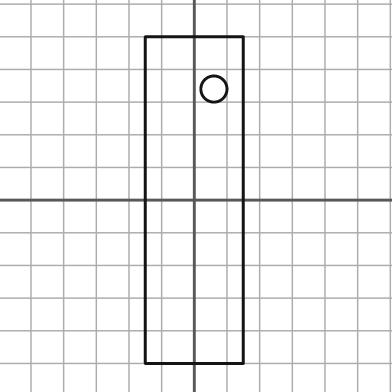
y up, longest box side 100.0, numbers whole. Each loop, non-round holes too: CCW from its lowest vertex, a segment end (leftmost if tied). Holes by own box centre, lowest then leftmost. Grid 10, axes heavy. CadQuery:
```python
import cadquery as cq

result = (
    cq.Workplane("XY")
    .moveTo(-15.0, -50.0)
    .lineTo(15.0, -50.0)
    .lineTo(15.0, 50.0)
    .lineTo(-15.0, 50.0)
    .close()
    .moveTo(6.0, 34.0)
    .circle(4.0)
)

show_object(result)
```